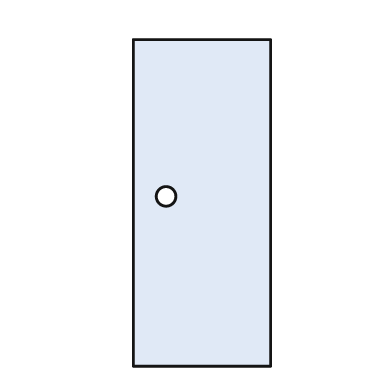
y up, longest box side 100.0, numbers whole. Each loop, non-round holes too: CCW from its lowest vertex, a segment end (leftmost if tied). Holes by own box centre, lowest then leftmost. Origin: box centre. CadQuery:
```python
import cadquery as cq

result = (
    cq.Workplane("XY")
    .moveTo(-21.0, -50.0)
    .lineTo(21.0, -50.0)
    .lineTo(21.0, 50.0)
    .lineTo(-21.0, 50.0)
    .close()
    .moveTo(-11.0, 2.0)
    .circle(3.0)
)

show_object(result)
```